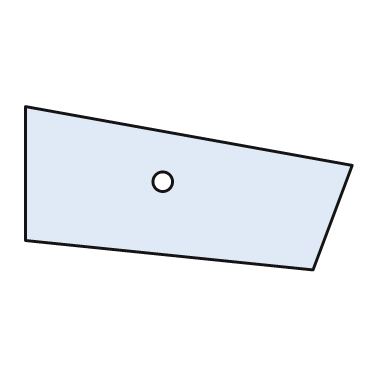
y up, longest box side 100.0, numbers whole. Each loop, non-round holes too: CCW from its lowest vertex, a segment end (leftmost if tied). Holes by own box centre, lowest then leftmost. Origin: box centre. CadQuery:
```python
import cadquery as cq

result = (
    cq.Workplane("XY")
    .moveTo(38.0, -25.0)
    .lineTo(50.0, 7.0)
    .lineTo(-50.0, 25.0)
    .lineTo(-50.0, -16.0)
    .close()
    .moveTo(-8.0, 2.0)
    .circle(3.0)
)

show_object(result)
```